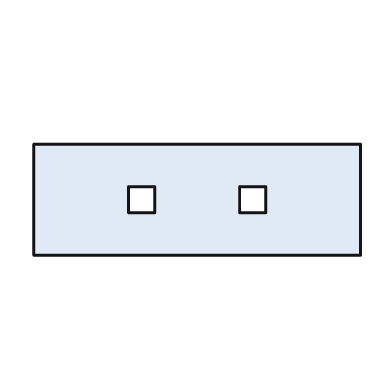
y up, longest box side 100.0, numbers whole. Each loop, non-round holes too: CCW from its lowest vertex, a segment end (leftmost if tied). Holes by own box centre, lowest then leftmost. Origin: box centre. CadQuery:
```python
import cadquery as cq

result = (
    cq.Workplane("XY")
    .moveTo(-50.0, -17.0)
    .lineTo(50.0, -17.0)
    .lineTo(50.0, 17.0)
    .lineTo(-50.0, 17.0)
    .close()
    .moveTo(-21.0, -4.0)
    .lineTo(-13.0, -4.0)
    .lineTo(-13.0, 4.0)
    .lineTo(-21.0, 4.0)
    .close()
    .moveTo(13.0, -4.0)
    .lineTo(21.0, -4.0)
    .lineTo(21.0, 4.0)
    .lineTo(13.0, 4.0)
    .close()
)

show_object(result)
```